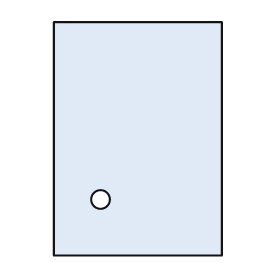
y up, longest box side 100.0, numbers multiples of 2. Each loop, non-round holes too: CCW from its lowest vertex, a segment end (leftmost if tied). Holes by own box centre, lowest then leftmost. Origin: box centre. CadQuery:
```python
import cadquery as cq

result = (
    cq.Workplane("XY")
    .moveTo(-36.0, -50.0)
    .lineTo(36.0, -50.0)
    .lineTo(36.0, 50.0)
    .lineTo(-36.0, 50.0)
    .close()
    .moveTo(-16.0, -26.0)
    .circle(4.0)
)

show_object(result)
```